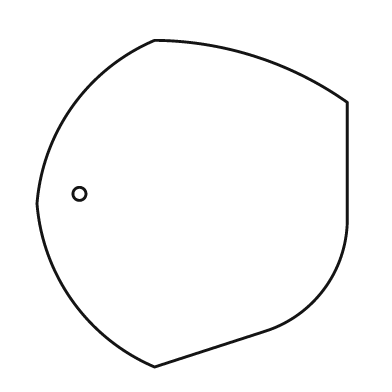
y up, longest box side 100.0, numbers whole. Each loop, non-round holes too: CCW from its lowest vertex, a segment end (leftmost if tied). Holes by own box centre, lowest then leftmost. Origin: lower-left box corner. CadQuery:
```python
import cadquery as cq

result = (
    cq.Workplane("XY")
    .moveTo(36.0, 0.0)
    .lineTo(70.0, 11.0)
    .threePointArc((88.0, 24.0), (95.0, 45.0))
    .lineTo(95.0, 81.0)
    .threePointArc((67.0, 95.0), (36.0, 100.0))
    .threePointArc((11.0, 80.0), (0.0, 50.0))
    .threePointArc((11.0, 20.0), (36.0, 0.0))
    .close()
    .moveTo(13.0, 53.0)
    .circle(2.0)
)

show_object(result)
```